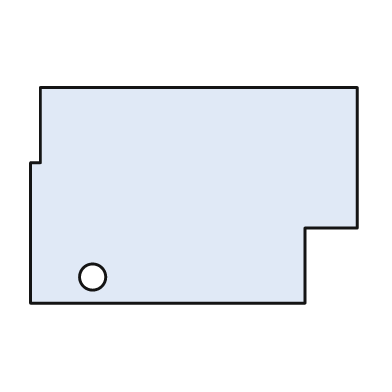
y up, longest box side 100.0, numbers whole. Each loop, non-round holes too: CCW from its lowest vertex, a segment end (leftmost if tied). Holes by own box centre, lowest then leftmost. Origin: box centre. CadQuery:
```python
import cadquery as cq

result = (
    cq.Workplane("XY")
    .moveTo(-50.0, -33.0)
    .lineTo(34.0, -33.0)
    .lineTo(34.0, -10.0)
    .lineTo(50.0, -10.0)
    .lineTo(50.0, 33.0)
    .lineTo(-47.0, 33.0)
    .lineTo(-47.0, 10.0)
    .lineTo(-50.0, 10.0)
    .close()
    .moveTo(-31.0, -25.0)
    .circle(4.0)
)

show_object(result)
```